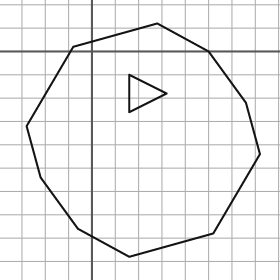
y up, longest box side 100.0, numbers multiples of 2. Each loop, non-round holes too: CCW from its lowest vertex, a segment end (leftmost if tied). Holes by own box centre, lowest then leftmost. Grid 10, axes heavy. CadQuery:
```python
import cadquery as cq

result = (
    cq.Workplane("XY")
    .moveTo(16.0, -88.0)
    .lineTo(52.0, -78.0)
    .lineTo(72.0, -44.0)
    .lineTo(66.0, -22.0)
    .lineTo(50.0, 0.0)
    .lineTo(28.0, 12.0)
    .lineTo(-8.0, 2.0)
    .lineTo(-28.0, -32.0)
    .lineTo(-22.0, -54.0)
    .lineTo(-6.0, -76.0)
    .close()
    .moveTo(16.0, -26.0)
    .lineTo(32.0, -18.0)
    .lineTo(16.0, -10.0)
    .close()
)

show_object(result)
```